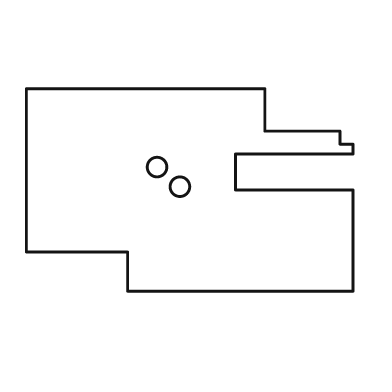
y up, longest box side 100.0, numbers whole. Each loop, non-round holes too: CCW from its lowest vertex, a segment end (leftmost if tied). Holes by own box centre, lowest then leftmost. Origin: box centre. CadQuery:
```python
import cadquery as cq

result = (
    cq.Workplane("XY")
    .moveTo(-19.0, -31.0)
    .lineTo(50.0, -31.0)
    .lineTo(50.0, 0.0)
    .lineTo(14.0, 0.0)
    .lineTo(14.0, 11.0)
    .lineTo(50.0, 11.0)
    .lineTo(50.0, 14.0)
    .lineTo(46.0, 14.0)
    .lineTo(46.0, 18.0)
    .lineTo(23.0, 18.0)
    .lineTo(23.0, 31.0)
    .lineTo(-50.0, 31.0)
    .lineTo(-50.0, -19.0)
    .lineTo(-19.0, -19.0)
    .close()
    .moveTo(-3.0, 1.0)
    .circle(3.0)
    .moveTo(-10.0, 7.0)
    .circle(3.0)
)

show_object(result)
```